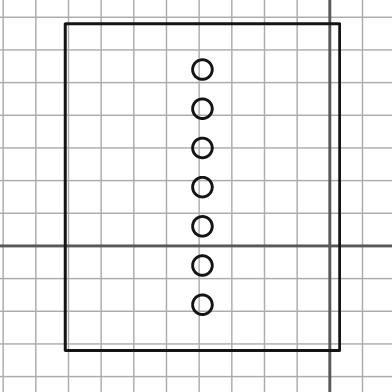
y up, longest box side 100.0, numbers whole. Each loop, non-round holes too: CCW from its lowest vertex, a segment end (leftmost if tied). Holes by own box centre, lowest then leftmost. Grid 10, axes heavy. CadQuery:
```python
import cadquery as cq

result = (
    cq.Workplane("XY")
    .moveTo(-81.0, -32.0)
    .lineTo(3.0, -32.0)
    .lineTo(3.0, 68.0)
    .lineTo(-81.0, 68.0)
    .close()
    .moveTo(-39.0, -18.0)
    .circle(3.0)
    .moveTo(-39.0, -6.0)
    .circle(3.0)
    .moveTo(-39.0, 6.0)
    .circle(3.0)
    .moveTo(-39.0, 18.0)
    .circle(3.0)
    .moveTo(-39.0, 30.0)
    .circle(3.0)
    .moveTo(-39.0, 42.0)
    .circle(3.0)
    .moveTo(-39.0, 54.0)
    .circle(3.0)
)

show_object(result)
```